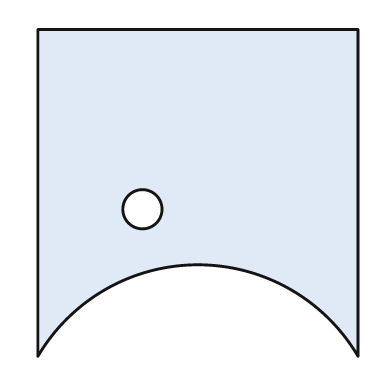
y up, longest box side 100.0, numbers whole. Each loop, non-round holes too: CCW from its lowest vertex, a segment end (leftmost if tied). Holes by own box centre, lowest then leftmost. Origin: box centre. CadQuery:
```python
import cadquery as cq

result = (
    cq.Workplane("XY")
    .moveTo(-49.0, -50.0)
    .threePointArc((0.0, -22.0), (49.0, -50.0))
    .lineTo(49.0, 50.0)
    .lineTo(-49.0, 50.0)
    .close()
    .moveTo(-17.0, -5.0)
    .circle(6.0)
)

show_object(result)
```